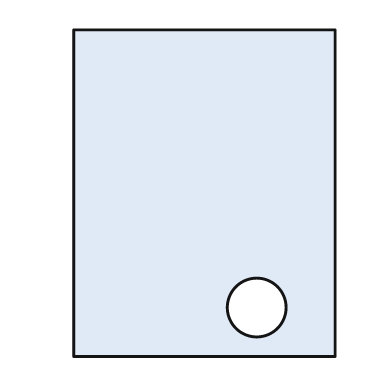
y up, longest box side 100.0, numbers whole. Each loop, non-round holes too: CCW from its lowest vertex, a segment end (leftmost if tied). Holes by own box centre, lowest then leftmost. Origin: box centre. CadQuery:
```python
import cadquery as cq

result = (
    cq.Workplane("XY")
    .moveTo(-40.0, -50.0)
    .lineTo(40.0, -50.0)
    .lineTo(40.0, 50.0)
    .lineTo(-40.0, 50.0)
    .close()
    .moveTo(16.0, -35.0)
    .circle(9.0)
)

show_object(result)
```